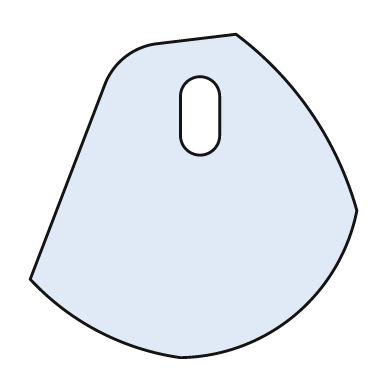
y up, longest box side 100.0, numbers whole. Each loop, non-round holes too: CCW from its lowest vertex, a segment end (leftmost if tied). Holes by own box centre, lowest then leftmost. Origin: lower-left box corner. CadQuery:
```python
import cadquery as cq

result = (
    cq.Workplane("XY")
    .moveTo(46.0, 0.0)
    .threePointArc((81.0, 13.0), (100.0, 45.0))
    .threePointArc((86.0, 75.0), (63.0, 99.0))
    .lineTo(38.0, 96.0)
    .threePointArc((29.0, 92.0), (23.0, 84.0))
    .lineTo(0.0, 24.0)
    .threePointArc((21.0, 8.0), (46.0, 0.0))
    .close()
    .moveTo(46.0, 68.0)
    .threePointArc((52.0, 62.0), (58.0, 68.0))
    .lineTo(58.0, 80.0)
    .threePointArc((52.0, 86.0), (46.0, 80.0))
    .close()
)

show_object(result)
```